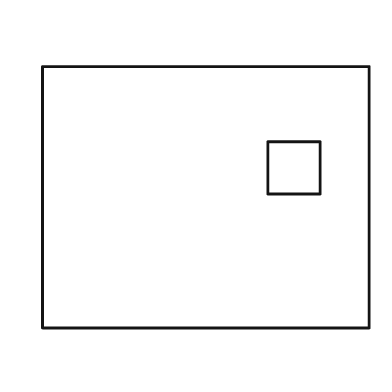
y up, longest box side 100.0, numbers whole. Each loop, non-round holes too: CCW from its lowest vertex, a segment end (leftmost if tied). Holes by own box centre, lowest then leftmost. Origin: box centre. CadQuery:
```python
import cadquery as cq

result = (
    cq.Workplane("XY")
    .moveTo(-50.0, -40.0)
    .lineTo(50.0, -40.0)
    .lineTo(50.0, 40.0)
    .lineTo(-50.0, 40.0)
    .close()
    .moveTo(19.0, 1.0)
    .lineTo(35.0, 1.0)
    .lineTo(35.0, 17.0)
    .lineTo(19.0, 17.0)
    .close()
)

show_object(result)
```